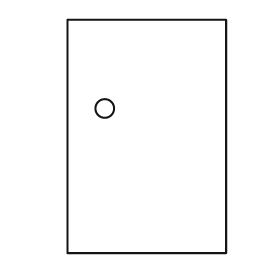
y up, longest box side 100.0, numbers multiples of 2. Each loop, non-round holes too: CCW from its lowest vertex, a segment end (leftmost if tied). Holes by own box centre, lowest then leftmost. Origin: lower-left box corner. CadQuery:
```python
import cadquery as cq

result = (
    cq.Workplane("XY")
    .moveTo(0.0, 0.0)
    .lineTo(68.0, 0.0)
    .lineTo(68.0, 100.0)
    .lineTo(0.0, 100.0)
    .close()
    .moveTo(16.0, 62.0)
    .circle(4.0)
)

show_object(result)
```